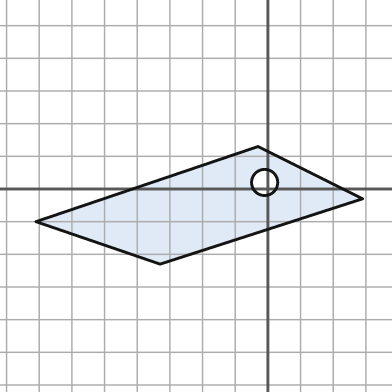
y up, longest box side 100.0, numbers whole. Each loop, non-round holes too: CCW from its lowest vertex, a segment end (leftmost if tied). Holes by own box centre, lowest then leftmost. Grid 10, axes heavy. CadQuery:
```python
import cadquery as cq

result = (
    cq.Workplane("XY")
    .moveTo(-33.0, -23.0)
    .lineTo(29.0, -3.0)
    .lineTo(-3.0, 13.0)
    .lineTo(-71.0, -10.0)
    .close()
    .moveTo(-1.0, 2.0)
    .circle(4.0)
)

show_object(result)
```